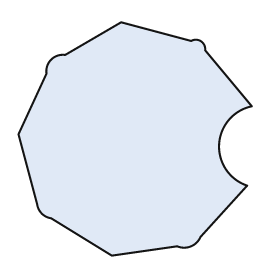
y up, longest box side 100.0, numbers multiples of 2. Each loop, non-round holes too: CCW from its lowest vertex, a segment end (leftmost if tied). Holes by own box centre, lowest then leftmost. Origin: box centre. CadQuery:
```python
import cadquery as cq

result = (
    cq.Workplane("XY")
    .moveTo(-10.0, -50.0)
    .lineTo(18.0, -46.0)
    .threePointArc((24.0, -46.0), (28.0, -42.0))
    .lineTo(48.0, -20.0)
    .threePointArc((36.0, -2.0), (50.0, 14.0))
    .lineTo(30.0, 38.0)
    .threePointArc((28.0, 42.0), (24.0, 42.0))
    .lineTo(-6.0, 50.0)
    .lineTo(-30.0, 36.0)
    .threePointArc((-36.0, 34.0), (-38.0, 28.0))
    .lineTo(-50.0, 2.0)
    .lineTo(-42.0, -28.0)
    .threePointArc((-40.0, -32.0), (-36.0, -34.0))
    .close()
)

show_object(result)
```